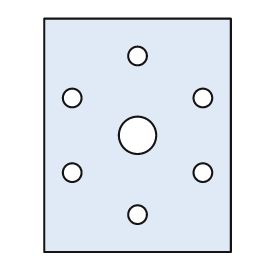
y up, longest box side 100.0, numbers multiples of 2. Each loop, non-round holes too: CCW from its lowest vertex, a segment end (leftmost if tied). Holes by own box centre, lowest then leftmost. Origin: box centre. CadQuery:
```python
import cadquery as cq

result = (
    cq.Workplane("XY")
    .moveTo(-40.0, -50.0)
    .lineTo(40.0, -50.0)
    .lineTo(40.0, 50.0)
    .lineTo(-40.0, 50.0)
    .close()
    .moveTo(0.0, -34.0)
    .circle(4.0)
    .moveTo(-28.0, -16.0)
    .circle(4.0)
    .moveTo(28.0, -16.0)
    .circle(4.0)
    .moveTo(0.0, 0.0)
    .circle(8.0)
    .moveTo(-28.0, 16.0)
    .circle(4.0)
    .moveTo(28.0, 16.0)
    .circle(4.0)
    .moveTo(0.0, 34.0)
    .circle(4.0)
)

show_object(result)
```